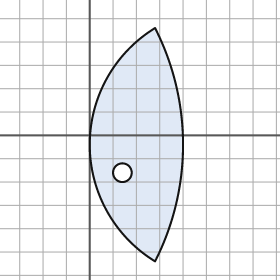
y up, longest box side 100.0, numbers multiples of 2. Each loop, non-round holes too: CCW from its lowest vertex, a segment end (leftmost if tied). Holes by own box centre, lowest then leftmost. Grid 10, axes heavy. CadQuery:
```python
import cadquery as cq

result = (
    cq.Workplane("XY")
    .moveTo(28.0, -54.0)
    .threePointArc((40.0, -4.0), (28.0, 46.0))
    .threePointArc((0.0, -4.0), (28.0, -54.0))
    .close()
    .moveTo(14.0, -16.0)
    .circle(4.0)
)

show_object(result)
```